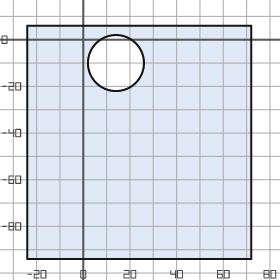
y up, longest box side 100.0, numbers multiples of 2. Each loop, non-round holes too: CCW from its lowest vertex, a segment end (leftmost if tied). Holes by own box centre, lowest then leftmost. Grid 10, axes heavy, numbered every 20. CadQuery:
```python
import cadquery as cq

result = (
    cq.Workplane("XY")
    .moveTo(-24.0, -94.0)
    .lineTo(72.0, -94.0)
    .lineTo(72.0, 6.0)
    .lineTo(-24.0, 6.0)
    .close()
    .moveTo(14.0, -10.0)
    .circle(12.0)
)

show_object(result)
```